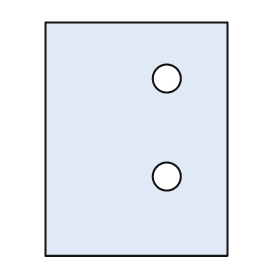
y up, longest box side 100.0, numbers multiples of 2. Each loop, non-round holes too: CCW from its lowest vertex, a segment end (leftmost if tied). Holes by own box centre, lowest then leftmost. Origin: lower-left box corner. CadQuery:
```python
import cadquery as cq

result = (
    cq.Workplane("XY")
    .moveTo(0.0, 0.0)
    .lineTo(78.0, 0.0)
    .lineTo(78.0, 100.0)
    .lineTo(0.0, 100.0)
    .close()
    .moveTo(52.0, 34.0)
    .circle(6.0)
    .moveTo(52.0, 76.0)
    .circle(6.0)
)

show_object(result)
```